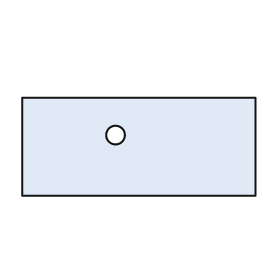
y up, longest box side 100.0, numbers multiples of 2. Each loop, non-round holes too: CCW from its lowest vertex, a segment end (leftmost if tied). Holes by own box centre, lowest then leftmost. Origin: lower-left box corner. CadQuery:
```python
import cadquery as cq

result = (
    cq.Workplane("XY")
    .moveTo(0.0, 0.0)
    .lineTo(100.0, 0.0)
    .lineTo(100.0, 42.0)
    .lineTo(0.0, 42.0)
    .close()
    .moveTo(40.0, 26.0)
    .circle(4.0)
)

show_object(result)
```